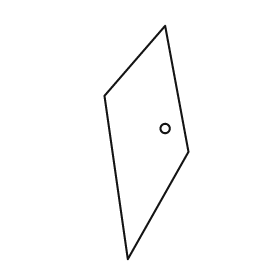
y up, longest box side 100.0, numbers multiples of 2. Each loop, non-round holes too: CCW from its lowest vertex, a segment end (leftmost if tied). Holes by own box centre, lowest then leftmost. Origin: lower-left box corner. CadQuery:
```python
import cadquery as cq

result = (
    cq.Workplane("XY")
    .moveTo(10.0, 0.0)
    .lineTo(36.0, 46.0)
    .lineTo(26.0, 100.0)
    .lineTo(0.0, 70.0)
    .close()
    .moveTo(26.0, 56.0)
    .circle(2.0)
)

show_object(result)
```